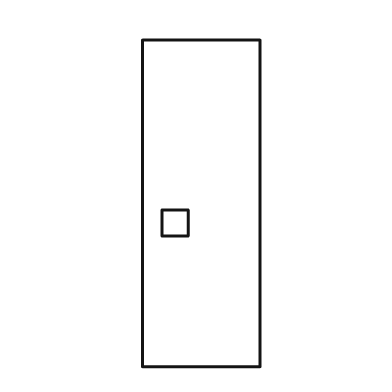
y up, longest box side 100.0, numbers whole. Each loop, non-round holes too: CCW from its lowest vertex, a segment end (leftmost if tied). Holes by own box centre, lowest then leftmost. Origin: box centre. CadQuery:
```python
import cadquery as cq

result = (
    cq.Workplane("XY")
    .moveTo(-18.0, -50.0)
    .lineTo(18.0, -50.0)
    .lineTo(18.0, 50.0)
    .lineTo(-18.0, 50.0)
    .close()
    .moveTo(-12.0, -10.0)
    .lineTo(-4.0, -10.0)
    .lineTo(-4.0, -2.0)
    .lineTo(-12.0, -2.0)
    .close()
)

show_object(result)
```